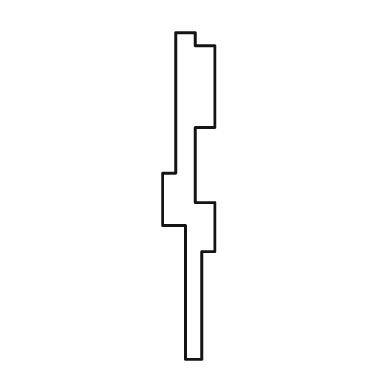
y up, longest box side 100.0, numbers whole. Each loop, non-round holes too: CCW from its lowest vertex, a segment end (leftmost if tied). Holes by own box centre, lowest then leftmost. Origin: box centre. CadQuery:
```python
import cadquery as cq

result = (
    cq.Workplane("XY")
    .moveTo(-1.0, -50.0)
    .lineTo(4.0, -50.0)
    .lineTo(4.0, -17.0)
    .lineTo(8.0, -17.0)
    .lineTo(8.0, -2.0)
    .lineTo(2.0, -2.0)
    .lineTo(2.0, 21.0)
    .lineTo(8.0, 21.0)
    .lineTo(8.0, 46.0)
    .lineTo(2.0, 46.0)
    .lineTo(2.0, 50.0)
    .lineTo(-4.0, 50.0)
    .lineTo(-4.0, 7.0)
    .lineTo(-8.0, 7.0)
    .lineTo(-8.0, -9.0)
    .lineTo(-1.0, -9.0)
    .close()
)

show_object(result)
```